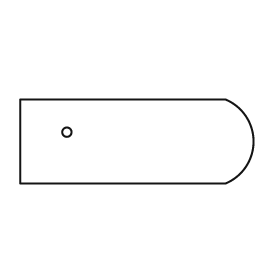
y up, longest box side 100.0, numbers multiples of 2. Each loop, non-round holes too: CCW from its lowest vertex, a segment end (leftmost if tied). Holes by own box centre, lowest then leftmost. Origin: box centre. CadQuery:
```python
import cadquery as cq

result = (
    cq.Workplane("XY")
    .moveTo(-50.0, -18.0)
    .lineTo(38.0, -18.0)
    .threePointArc((50.0, 0.0), (38.0, 18.0))
    .lineTo(-50.0, 18.0)
    .close()
    .moveTo(-30.0, 4.0)
    .circle(2.0)
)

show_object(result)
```